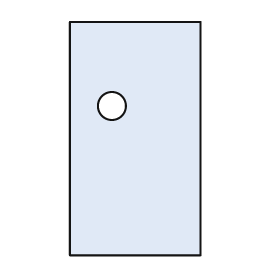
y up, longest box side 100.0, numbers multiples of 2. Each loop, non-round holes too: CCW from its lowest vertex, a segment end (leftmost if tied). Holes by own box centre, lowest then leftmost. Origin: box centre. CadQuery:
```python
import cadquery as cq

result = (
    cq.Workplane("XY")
    .moveTo(-28.0, -50.0)
    .lineTo(28.0, -50.0)
    .lineTo(28.0, 50.0)
    .lineTo(-28.0, 50.0)
    .close()
    .moveTo(-10.0, 14.0)
    .circle(6.0)
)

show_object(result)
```